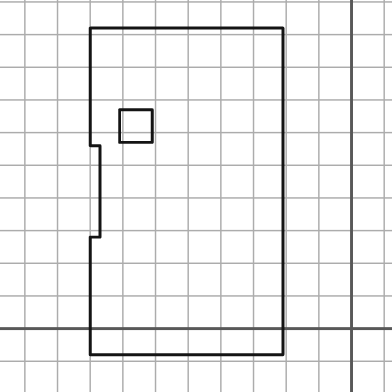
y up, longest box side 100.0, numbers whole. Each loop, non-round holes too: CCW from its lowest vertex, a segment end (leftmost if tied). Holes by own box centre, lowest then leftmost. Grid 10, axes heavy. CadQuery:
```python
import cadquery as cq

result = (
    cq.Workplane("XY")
    .moveTo(-80.0, -8.0)
    .lineTo(-21.0, -8.0)
    .lineTo(-21.0, 92.0)
    .lineTo(-80.0, 92.0)
    .lineTo(-80.0, 56.0)
    .lineTo(-77.0, 56.0)
    .lineTo(-77.0, 28.0)
    .lineTo(-80.0, 28.0)
    .close()
    .moveTo(-71.0, 57.0)
    .lineTo(-61.0, 57.0)
    .lineTo(-61.0, 67.0)
    .lineTo(-71.0, 67.0)
    .close()
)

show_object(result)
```